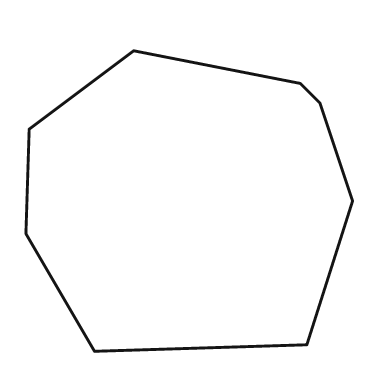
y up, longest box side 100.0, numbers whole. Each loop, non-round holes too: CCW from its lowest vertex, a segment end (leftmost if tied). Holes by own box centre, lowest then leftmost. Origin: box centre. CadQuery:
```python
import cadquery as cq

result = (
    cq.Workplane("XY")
    .moveTo(-29.0, -46.0)
    .lineTo(36.0, -44.0)
    .lineTo(50.0, 0.0)
    .lineTo(40.0, 30.0)
    .lineTo(34.0, 36.0)
    .lineTo(-17.0, 46.0)
    .lineTo(-49.0, 22.0)
    .lineTo(-50.0, -10.0)
    .close()
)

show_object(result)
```